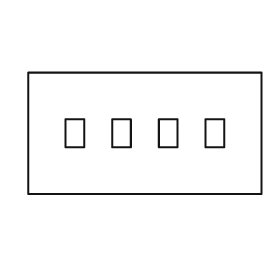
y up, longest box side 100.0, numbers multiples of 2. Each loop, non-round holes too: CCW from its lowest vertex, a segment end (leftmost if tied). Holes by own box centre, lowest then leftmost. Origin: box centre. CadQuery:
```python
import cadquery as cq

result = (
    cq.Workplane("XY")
    .moveTo(-50.0, -26.0)
    .lineTo(50.0, -26.0)
    .lineTo(50.0, 26.0)
    .lineTo(-50.0, 26.0)
    .close()
    .moveTo(-34.0, -6.0)
    .lineTo(-26.0, -6.0)
    .lineTo(-26.0, 6.0)
    .lineTo(-34.0, 6.0)
    .close()
    .moveTo(-14.0, -6.0)
    .lineTo(-6.0, -6.0)
    .lineTo(-6.0, 6.0)
    .lineTo(-14.0, 6.0)
    .close()
    .moveTo(6.0, -6.0)
    .lineTo(14.0, -6.0)
    .lineTo(14.0, 6.0)
    .lineTo(6.0, 6.0)
    .close()
    .moveTo(26.0, -6.0)
    .lineTo(34.0, -6.0)
    .lineTo(34.0, 6.0)
    .lineTo(26.0, 6.0)
    .close()
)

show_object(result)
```